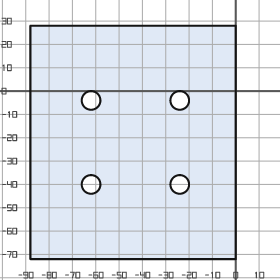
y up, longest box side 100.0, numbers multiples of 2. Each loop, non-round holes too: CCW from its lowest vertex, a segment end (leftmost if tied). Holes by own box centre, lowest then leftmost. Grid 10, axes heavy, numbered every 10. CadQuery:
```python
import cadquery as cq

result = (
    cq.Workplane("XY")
    .moveTo(-88.0, -72.0)
    .lineTo(0.0, -72.0)
    .lineTo(0.0, 28.0)
    .lineTo(-88.0, 28.0)
    .close()
    .moveTo(-62.0, -40.0)
    .circle(4.0)
    .moveTo(-24.0, -40.0)
    .circle(4.0)
    .moveTo(-62.0, -4.0)
    .circle(4.0)
    .moveTo(-24.0, -4.0)
    .circle(4.0)
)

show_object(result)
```